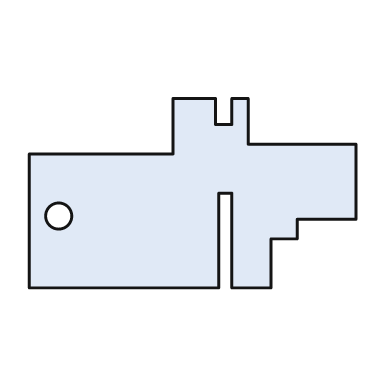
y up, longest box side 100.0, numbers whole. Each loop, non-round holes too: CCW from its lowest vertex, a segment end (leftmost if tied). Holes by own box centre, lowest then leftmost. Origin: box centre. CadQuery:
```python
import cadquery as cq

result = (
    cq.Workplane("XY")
    .moveTo(-50.0, -29.0)
    .lineTo(8.0, -29.0)
    .lineTo(8.0, 0.0)
    .lineTo(12.0, 0.0)
    .lineTo(12.0, -29.0)
    .lineTo(24.0, -29.0)
    .lineTo(24.0, -14.0)
    .lineTo(32.0, -14.0)
    .lineTo(32.0, -8.0)
    .lineTo(50.0, -8.0)
    .lineTo(50.0, 15.0)
    .lineTo(17.0, 15.0)
    .lineTo(17.0, 29.0)
    .lineTo(12.0, 29.0)
    .lineTo(12.0, 21.0)
    .lineTo(7.0, 21.0)
    .lineTo(7.0, 29.0)
    .lineTo(-6.0, 29.0)
    .lineTo(-6.0, 12.0)
    .lineTo(-50.0, 12.0)
    .close()
    .moveTo(-41.0, -7.0)
    .circle(4.0)
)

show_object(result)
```